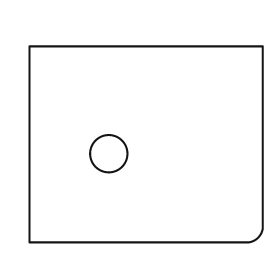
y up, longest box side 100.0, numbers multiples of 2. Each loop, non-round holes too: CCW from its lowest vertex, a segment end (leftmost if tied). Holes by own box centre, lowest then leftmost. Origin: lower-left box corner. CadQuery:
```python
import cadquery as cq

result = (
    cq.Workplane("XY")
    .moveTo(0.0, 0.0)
    .lineTo(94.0, 0.0)
    .threePointArc((98.0, 2.0), (100.0, 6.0))
    .lineTo(100.0, 84.0)
    .lineTo(0.0, 84.0)
    .close()
    .moveTo(34.0, 38.0)
    .circle(8.0)
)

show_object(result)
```